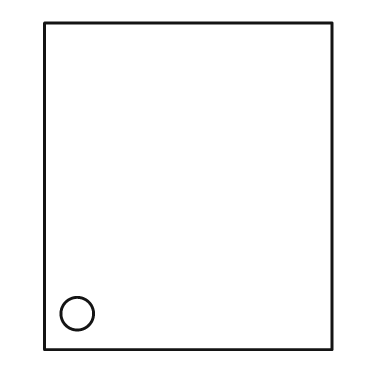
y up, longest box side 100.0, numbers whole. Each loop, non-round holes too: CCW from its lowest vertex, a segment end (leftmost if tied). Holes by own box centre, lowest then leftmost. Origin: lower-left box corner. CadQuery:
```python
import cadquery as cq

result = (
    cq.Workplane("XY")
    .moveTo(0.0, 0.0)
    .lineTo(88.0, 0.0)
    .lineTo(88.0, 100.0)
    .lineTo(0.0, 100.0)
    .close()
    .moveTo(10.0, 11.0)
    .circle(5.0)
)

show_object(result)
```